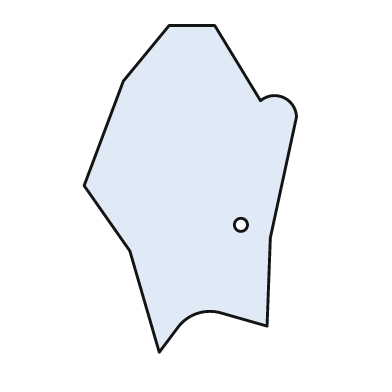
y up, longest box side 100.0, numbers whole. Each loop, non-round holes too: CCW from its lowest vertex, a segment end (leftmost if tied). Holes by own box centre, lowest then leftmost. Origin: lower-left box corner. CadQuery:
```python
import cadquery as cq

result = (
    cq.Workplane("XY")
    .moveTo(23.0, 0.0)
    .lineTo(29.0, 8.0)
    .threePointArc((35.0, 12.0), (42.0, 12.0))
    .lineTo(56.0, 8.0)
    .lineTo(57.0, 35.0)
    .lineTo(65.0, 72.0)
    .threePointArc((61.0, 78.0), (54.0, 77.0))
    .lineTo(40.0, 100.0)
    .lineTo(26.0, 100.0)
    .lineTo(12.0, 83.0)
    .lineTo(0.0, 51.0)
    .lineTo(14.0, 31.0)
    .close()
    .moveTo(48.0, 39.0)
    .circle(2.0)
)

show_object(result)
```